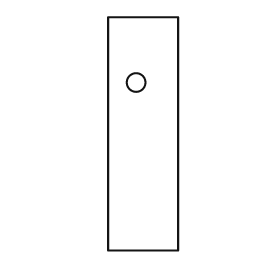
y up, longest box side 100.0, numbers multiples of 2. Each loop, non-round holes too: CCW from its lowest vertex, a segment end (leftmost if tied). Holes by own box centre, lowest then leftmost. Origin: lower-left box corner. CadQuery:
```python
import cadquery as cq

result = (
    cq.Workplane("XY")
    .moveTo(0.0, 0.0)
    .lineTo(30.0, 0.0)
    .lineTo(30.0, 100.0)
    .lineTo(0.0, 100.0)
    .close()
    .moveTo(12.0, 72.0)
    .circle(4.0)
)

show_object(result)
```